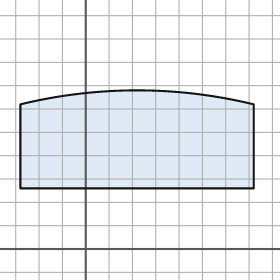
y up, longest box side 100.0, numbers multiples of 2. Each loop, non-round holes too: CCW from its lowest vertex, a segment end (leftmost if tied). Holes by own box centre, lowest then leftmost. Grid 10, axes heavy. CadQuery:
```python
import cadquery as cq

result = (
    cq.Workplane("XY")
    .moveTo(-28.0, 26.0)
    .lineTo(72.0, 26.0)
    .lineTo(72.0, 62.0)
    .threePointArc((22.0, 68.0), (-28.0, 62.0))
    .close()
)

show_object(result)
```